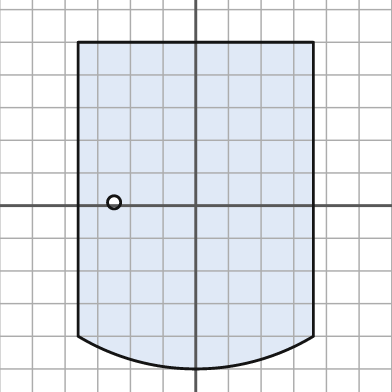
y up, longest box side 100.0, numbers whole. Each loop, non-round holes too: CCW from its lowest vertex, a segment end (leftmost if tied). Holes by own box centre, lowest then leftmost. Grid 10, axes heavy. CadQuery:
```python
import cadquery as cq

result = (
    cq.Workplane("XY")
    .moveTo(-36.0, -40.0)
    .threePointArc((0.0, -50.0), (36.0, -40.0))
    .lineTo(36.0, 50.0)
    .lineTo(-36.0, 50.0)
    .close()
    .moveTo(-25.0, 1.0)
    .circle(2.0)
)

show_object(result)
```